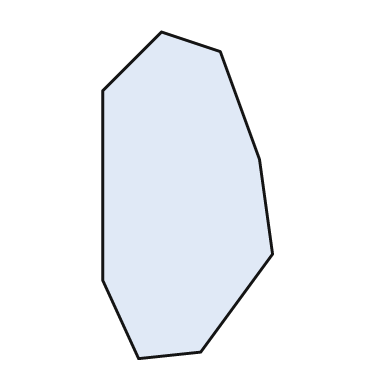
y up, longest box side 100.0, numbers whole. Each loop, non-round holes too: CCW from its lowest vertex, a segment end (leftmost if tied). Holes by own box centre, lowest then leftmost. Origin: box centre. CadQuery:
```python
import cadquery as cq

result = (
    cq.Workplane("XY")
    .moveTo(-15.0, -50.0)
    .lineTo(4.0, -48.0)
    .lineTo(26.0, -18.0)
    .lineTo(22.0, 11.0)
    .lineTo(10.0, 44.0)
    .lineTo(-8.0, 50.0)
    .lineTo(-26.0, 32.0)
    .lineTo(-26.0, -26.0)
    .close()
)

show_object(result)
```